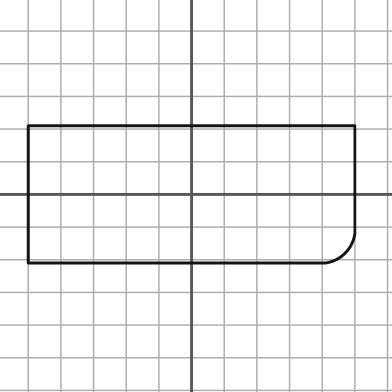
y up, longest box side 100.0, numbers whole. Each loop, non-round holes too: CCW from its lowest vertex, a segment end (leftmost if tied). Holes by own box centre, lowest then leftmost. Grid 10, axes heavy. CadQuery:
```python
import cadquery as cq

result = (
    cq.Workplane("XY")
    .moveTo(-50.0, -21.0)
    .lineTo(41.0, -21.0)
    .threePointArc((47.0, -18.0), (50.0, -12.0))
    .lineTo(50.0, 21.0)
    .lineTo(-50.0, 21.0)
    .close()
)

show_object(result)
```